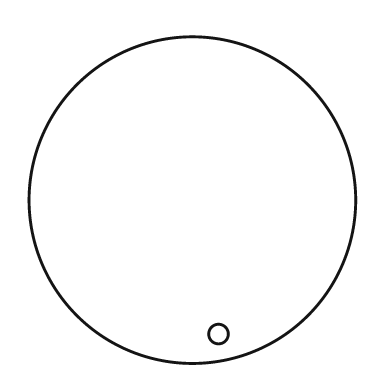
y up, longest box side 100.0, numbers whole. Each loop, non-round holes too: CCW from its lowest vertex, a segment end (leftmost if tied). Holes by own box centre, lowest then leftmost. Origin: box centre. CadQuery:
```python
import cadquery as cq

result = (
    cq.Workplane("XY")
    .moveTo(0.0, 0.0)
    .circle(50.0)
    .moveTo(8.0, -41.0)
    .circle(3.0)
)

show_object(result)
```